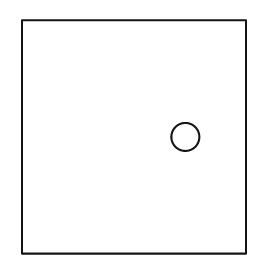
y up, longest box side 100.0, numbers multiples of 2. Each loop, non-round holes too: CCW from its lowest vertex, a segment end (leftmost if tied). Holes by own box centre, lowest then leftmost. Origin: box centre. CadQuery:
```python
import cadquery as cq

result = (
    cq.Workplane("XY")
    .moveTo(-48.0, -50.0)
    .lineTo(48.0, -50.0)
    .lineTo(48.0, 50.0)
    .lineTo(-48.0, 50.0)
    .close()
    .moveTo(22.0, 0.0)
    .circle(6.0)
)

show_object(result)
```